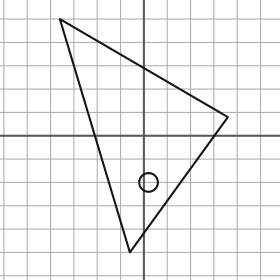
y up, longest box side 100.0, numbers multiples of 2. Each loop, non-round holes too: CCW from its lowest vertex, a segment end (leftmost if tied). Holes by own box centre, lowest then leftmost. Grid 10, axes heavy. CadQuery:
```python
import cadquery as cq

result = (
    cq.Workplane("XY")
    .moveTo(-6.0, -50.0)
    .lineTo(36.0, 8.0)
    .lineTo(-36.0, 50.0)
    .close()
    .moveTo(2.0, -20.0)
    .circle(4.0)
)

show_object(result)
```